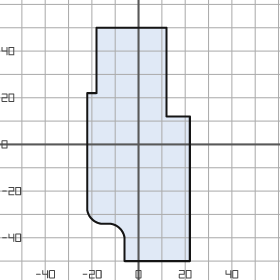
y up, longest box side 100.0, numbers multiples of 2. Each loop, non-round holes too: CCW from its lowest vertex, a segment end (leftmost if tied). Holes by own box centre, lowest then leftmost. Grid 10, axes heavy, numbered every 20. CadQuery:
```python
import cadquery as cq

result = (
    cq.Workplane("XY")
    .moveTo(-6.0, -50.0)
    .lineTo(22.0, -50.0)
    .lineTo(22.0, 12.0)
    .lineTo(12.0, 12.0)
    .lineTo(12.0, 50.0)
    .lineTo(-18.0, 50.0)
    .lineTo(-18.0, 22.0)
    .lineTo(-22.0, 22.0)
    .lineTo(-22.0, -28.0)
    .threePointArc((-20.0, -32.0), (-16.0, -34.0))
    .lineTo(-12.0, -34.0)
    .threePointArc((-8.0, -36.0), (-6.0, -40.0))
    .close()
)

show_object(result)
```